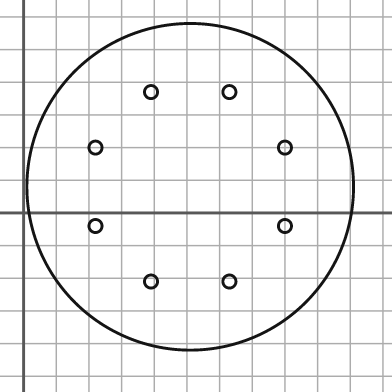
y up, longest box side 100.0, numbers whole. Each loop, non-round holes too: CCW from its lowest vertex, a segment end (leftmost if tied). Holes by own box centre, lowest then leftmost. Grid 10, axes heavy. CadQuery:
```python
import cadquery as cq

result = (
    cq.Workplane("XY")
    .moveTo(51.0, 8.0)
    .circle(50.0)
    .moveTo(39.0, -21.0)
    .circle(2.0)
    .moveTo(63.0, -21.0)
    .circle(2.0)
    .moveTo(22.0, -4.0)
    .circle(2.0)
    .moveTo(80.0, -4.0)
    .circle(2.0)
    .moveTo(22.0, 20.0)
    .circle(2.0)
    .moveTo(80.0, 20.0)
    .circle(2.0)
    .moveTo(39.0, 37.0)
    .circle(2.0)
    .moveTo(63.0, 37.0)
    .circle(2.0)
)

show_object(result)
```